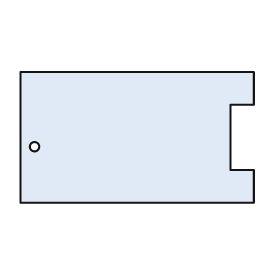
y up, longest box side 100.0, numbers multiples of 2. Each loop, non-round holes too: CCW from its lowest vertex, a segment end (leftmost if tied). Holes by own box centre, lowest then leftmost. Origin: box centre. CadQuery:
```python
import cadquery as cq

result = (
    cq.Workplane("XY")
    .moveTo(-50.0, -28.0)
    .lineTo(50.0, -28.0)
    .lineTo(50.0, -14.0)
    .lineTo(40.0, -14.0)
    .lineTo(40.0, 14.0)
    .lineTo(50.0, 14.0)
    .lineTo(50.0, 28.0)
    .lineTo(-50.0, 28.0)
    .close()
    .moveTo(-44.0, -4.0)
    .circle(2.0)
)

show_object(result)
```